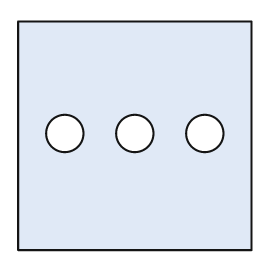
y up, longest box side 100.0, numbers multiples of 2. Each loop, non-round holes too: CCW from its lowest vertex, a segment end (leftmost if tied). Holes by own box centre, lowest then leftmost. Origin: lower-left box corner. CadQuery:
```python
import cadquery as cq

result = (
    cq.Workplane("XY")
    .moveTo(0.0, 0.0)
    .lineTo(100.0, 0.0)
    .lineTo(100.0, 98.0)
    .lineTo(0.0, 98.0)
    .close()
    .moveTo(20.0, 50.0)
    .circle(8.0)
    .moveTo(50.0, 50.0)
    .circle(8.0)
    .moveTo(80.0, 50.0)
    .circle(8.0)
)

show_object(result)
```